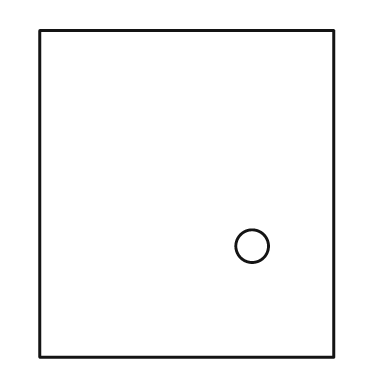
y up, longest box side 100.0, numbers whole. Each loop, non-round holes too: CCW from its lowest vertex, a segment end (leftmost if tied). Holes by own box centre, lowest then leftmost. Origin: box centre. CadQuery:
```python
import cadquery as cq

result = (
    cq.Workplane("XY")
    .moveTo(-45.0, -50.0)
    .lineTo(45.0, -50.0)
    .lineTo(45.0, 50.0)
    .lineTo(-45.0, 50.0)
    .close()
    .moveTo(20.0, -16.0)
    .circle(5.0)
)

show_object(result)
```